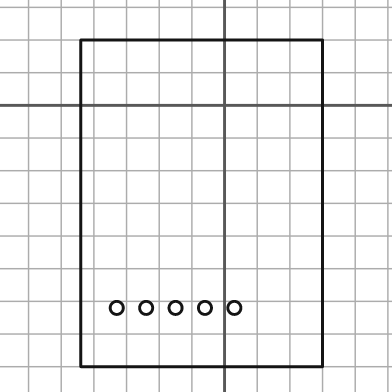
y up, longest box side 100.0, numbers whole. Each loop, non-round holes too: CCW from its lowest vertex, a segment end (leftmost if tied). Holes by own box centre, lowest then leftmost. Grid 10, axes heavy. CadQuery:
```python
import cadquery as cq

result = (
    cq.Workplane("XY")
    .moveTo(-44.0, -80.0)
    .lineTo(30.0, -80.0)
    .lineTo(30.0, 20.0)
    .lineTo(-44.0, 20.0)
    .close()
    .moveTo(-33.0, -62.0)
    .circle(2.0)
    .moveTo(-24.0, -62.0)
    .circle(2.0)
    .moveTo(-15.0, -62.0)
    .circle(2.0)
    .moveTo(-6.0, -62.0)
    .circle(2.0)
    .moveTo(3.0, -62.0)
    .circle(2.0)
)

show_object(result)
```